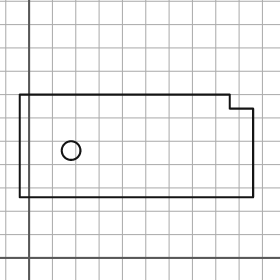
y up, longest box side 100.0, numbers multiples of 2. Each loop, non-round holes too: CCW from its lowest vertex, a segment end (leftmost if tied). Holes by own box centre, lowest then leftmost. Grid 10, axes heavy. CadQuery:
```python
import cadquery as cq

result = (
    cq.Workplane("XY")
    .moveTo(-4.0, 26.0)
    .lineTo(96.0, 26.0)
    .lineTo(96.0, 64.0)
    .lineTo(86.0, 64.0)
    .lineTo(86.0, 70.0)
    .lineTo(-4.0, 70.0)
    .close()
    .moveTo(18.0, 46.0)
    .circle(4.0)
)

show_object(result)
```